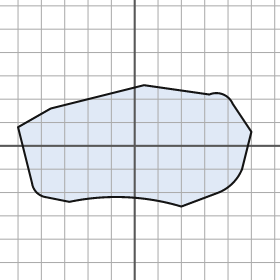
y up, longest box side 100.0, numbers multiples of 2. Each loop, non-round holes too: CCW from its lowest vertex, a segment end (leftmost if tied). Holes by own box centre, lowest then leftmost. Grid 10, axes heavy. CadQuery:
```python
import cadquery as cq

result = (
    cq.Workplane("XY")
    .moveTo(20.0, -26.0)
    .lineTo(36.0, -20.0)
    .threePointArc((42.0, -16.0), (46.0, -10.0))
    .lineTo(50.0, 6.0)
    .lineTo(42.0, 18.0)
    .threePointArc((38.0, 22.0), (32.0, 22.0))
    .lineTo(4.0, 26.0)
    .lineTo(-36.0, 16.0)
    .lineTo(-50.0, 8.0)
    .lineTo(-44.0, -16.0)
    .threePointArc((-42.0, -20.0), (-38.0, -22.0))
    .lineTo(-28.0, -24.0)
    .threePointArc((-4.0, -22.0), (20.0, -26.0))
    .close()
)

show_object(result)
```